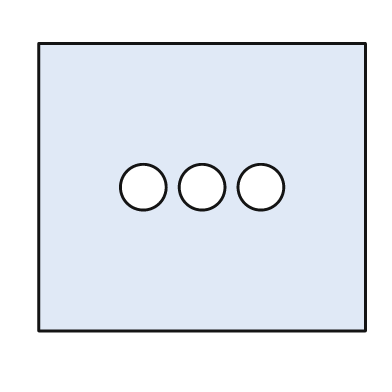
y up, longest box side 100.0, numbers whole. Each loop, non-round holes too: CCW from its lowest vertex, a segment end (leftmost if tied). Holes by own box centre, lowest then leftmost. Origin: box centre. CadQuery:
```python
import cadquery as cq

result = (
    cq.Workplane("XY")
    .moveTo(-50.0, -44.0)
    .lineTo(50.0, -44.0)
    .lineTo(50.0, 44.0)
    .lineTo(-50.0, 44.0)
    .close()
    .moveTo(-18.0, 0.0)
    .circle(7.0)
    .moveTo(0.0, 0.0)
    .circle(7.0)
    .moveTo(18.0, 0.0)
    .circle(7.0)
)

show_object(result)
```